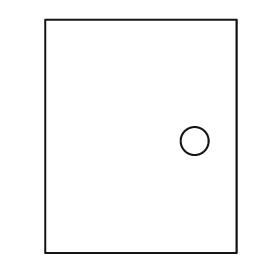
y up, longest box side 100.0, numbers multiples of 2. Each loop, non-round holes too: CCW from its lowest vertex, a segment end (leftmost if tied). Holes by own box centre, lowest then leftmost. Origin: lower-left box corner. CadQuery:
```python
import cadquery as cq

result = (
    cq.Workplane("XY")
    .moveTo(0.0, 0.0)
    .lineTo(82.0, 0.0)
    .lineTo(82.0, 100.0)
    .lineTo(0.0, 100.0)
    .close()
    .moveTo(64.0, 48.0)
    .circle(6.0)
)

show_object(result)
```